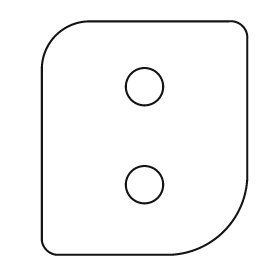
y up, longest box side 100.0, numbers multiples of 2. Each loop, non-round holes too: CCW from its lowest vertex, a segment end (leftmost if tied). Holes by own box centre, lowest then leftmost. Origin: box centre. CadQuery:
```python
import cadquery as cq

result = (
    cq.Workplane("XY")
    .moveTo(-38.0, -50.0)
    .lineTo(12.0, -50.0)
    .threePointArc((34.0, -40.0), (44.0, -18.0))
    .lineTo(44.0, 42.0)
    .threePointArc((42.0, 48.0), (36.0, 50.0))
    .lineTo(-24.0, 50.0)
    .threePointArc((-38.0, 44.0), (-44.0, 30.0))
    .lineTo(-44.0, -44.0)
    .threePointArc((-42.0, -48.0), (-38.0, -50.0))
    .close()
    .moveTo(0.0, -20.0)
    .circle(8.0)
    .moveTo(0.0, 22.0)
    .circle(8.0)
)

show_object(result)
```